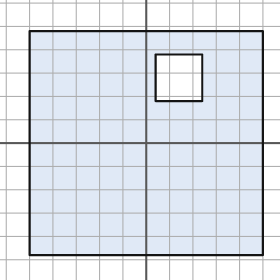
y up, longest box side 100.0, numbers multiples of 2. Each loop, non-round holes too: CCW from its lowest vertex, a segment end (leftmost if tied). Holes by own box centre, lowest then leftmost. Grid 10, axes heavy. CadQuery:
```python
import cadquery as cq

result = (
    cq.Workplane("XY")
    .moveTo(-50.0, -48.0)
    .lineTo(50.0, -48.0)
    .lineTo(50.0, 48.0)
    .lineTo(-50.0, 48.0)
    .close()
    .moveTo(4.0, 18.0)
    .lineTo(24.0, 18.0)
    .lineTo(24.0, 38.0)
    .lineTo(4.0, 38.0)
    .close()
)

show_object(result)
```